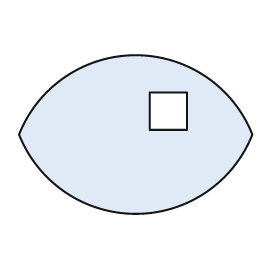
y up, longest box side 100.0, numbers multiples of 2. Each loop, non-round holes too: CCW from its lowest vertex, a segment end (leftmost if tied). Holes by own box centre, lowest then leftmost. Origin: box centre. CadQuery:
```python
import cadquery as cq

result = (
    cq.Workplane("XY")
    .moveTo(-50.0, 0.0)
    .threePointArc((0.0, -34.0), (50.0, 0.0))
    .threePointArc((0.0, 34.0), (-50.0, 0.0))
    .close()
    .moveTo(6.0, 2.0)
    .lineTo(22.0, 2.0)
    .lineTo(22.0, 18.0)
    .lineTo(6.0, 18.0)
    .close()
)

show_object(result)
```